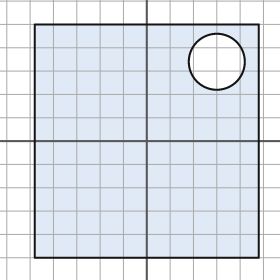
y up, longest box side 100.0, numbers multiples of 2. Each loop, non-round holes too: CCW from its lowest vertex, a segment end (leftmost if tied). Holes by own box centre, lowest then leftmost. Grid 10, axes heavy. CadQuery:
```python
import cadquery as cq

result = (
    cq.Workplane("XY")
    .moveTo(-48.0, -50.0)
    .lineTo(48.0, -50.0)
    .lineTo(48.0, 50.0)
    .lineTo(-48.0, 50.0)
    .close()
    .moveTo(30.0, 34.0)
    .circle(12.0)
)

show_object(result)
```